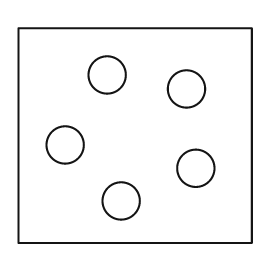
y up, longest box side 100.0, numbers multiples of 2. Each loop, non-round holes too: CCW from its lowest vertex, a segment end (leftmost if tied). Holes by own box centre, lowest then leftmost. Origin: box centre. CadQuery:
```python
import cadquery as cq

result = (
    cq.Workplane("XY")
    .moveTo(-50.0, -46.0)
    .lineTo(50.0, -46.0)
    .lineTo(50.0, 46.0)
    .lineTo(-50.0, 46.0)
    .close()
    .moveTo(-6.0, -28.0)
    .circle(8.0)
    .moveTo(26.0, -14.0)
    .circle(8.0)
    .moveTo(-30.0, -4.0)
    .circle(8.0)
    .moveTo(22.0, 20.0)
    .circle(8.0)
    .moveTo(-12.0, 26.0)
    .circle(8.0)
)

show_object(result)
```